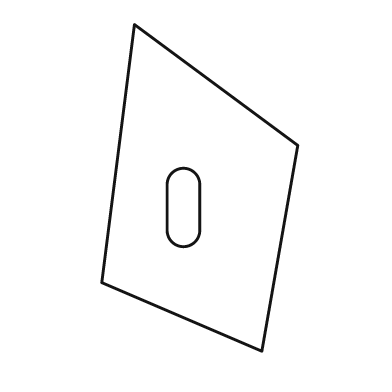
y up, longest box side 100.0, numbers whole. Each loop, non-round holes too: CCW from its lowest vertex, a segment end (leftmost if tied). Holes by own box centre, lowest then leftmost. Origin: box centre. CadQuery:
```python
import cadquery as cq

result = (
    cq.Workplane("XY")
    .moveTo(19.0, -50.0)
    .lineTo(30.0, 13.0)
    .lineTo(-20.0, 50.0)
    .lineTo(-30.0, -29.0)
    .close()
    .moveTo(-10.0, -13.0)
    .threePointArc((-5.0, -18.0), (0.0, -13.0))
    .lineTo(0.0, 1.0)
    .threePointArc((-5.0, 6.0), (-10.0, 1.0))
    .close()
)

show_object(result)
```